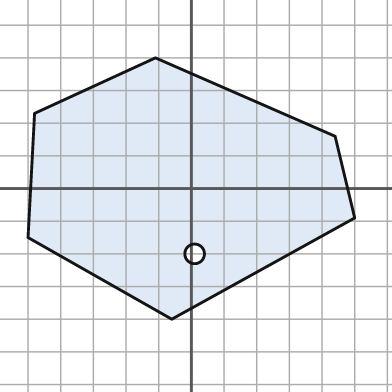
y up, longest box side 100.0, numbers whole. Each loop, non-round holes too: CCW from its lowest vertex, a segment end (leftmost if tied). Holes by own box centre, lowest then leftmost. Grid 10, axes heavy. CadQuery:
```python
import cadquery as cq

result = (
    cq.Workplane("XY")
    .moveTo(-6.0, -40.0)
    .lineTo(50.0, -9.0)
    .lineTo(44.0, 16.0)
    .lineTo(-11.0, 40.0)
    .lineTo(-48.0, 23.0)
    .lineTo(-50.0, -15.0)
    .close()
    .moveTo(1.0, -20.0)
    .circle(3.0)
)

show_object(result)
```